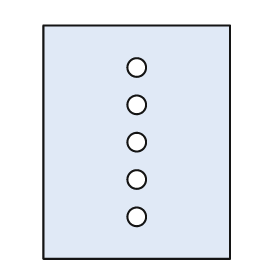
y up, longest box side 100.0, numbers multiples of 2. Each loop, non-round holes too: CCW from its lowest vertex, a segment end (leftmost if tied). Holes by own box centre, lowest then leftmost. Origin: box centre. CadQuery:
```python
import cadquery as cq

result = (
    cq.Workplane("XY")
    .moveTo(-40.0, -50.0)
    .lineTo(40.0, -50.0)
    .lineTo(40.0, 50.0)
    .lineTo(-40.0, 50.0)
    .close()
    .moveTo(0.0, -32.0)
    .circle(4.0)
    .moveTo(0.0, -16.0)
    .circle(4.0)
    .moveTo(0.0, 0.0)
    .circle(4.0)
    .moveTo(0.0, 16.0)
    .circle(4.0)
    .moveTo(0.0, 32.0)
    .circle(4.0)
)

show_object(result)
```